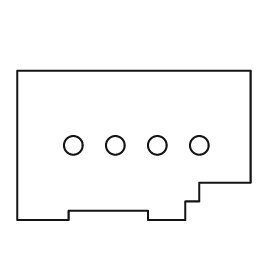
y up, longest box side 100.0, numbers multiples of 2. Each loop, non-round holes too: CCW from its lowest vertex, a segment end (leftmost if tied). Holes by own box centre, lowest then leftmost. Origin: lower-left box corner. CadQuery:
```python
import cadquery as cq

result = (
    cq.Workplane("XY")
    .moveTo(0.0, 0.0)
    .lineTo(22.0, 0.0)
    .lineTo(22.0, 4.0)
    .lineTo(56.0, 4.0)
    .lineTo(56.0, 0.0)
    .lineTo(72.0, 0.0)
    .lineTo(72.0, 8.0)
    .lineTo(78.0, 8.0)
    .lineTo(78.0, 16.0)
    .lineTo(100.0, 16.0)
    .lineTo(100.0, 64.0)
    .lineTo(0.0, 64.0)
    .close()
    .moveTo(24.0, 32.0)
    .circle(4.0)
    .moveTo(42.0, 32.0)
    .circle(4.0)
    .moveTo(60.0, 32.0)
    .circle(4.0)
    .moveTo(78.0, 32.0)
    .circle(4.0)
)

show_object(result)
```